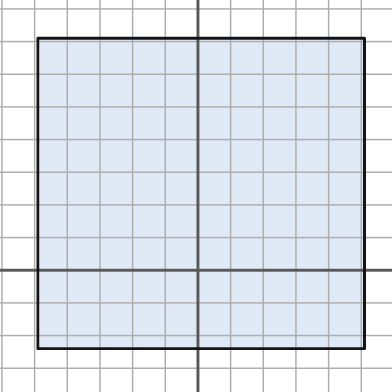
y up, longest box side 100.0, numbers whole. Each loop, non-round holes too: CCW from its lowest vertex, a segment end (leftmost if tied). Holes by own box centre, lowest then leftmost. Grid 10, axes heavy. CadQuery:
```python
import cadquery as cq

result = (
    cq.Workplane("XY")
    .moveTo(-49.0, -24.0)
    .lineTo(51.0, -24.0)
    .lineTo(51.0, 71.0)
    .lineTo(-49.0, 71.0)
    .close()
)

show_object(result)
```